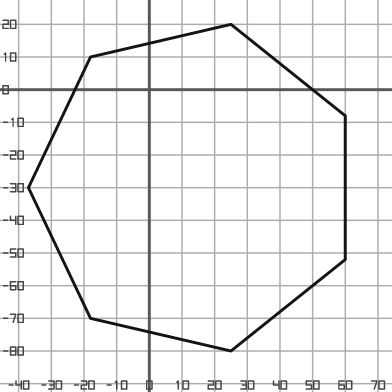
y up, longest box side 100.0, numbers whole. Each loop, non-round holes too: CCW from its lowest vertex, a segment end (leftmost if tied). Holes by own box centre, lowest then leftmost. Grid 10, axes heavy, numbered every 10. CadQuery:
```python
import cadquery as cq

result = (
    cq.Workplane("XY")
    .moveTo(25.0, -80.0)
    .lineTo(60.0, -52.0)
    .lineTo(60.0, -8.0)
    .lineTo(25.0, 20.0)
    .lineTo(-18.0, 10.0)
    .lineTo(-37.0, -30.0)
    .lineTo(-18.0, -70.0)
    .close()
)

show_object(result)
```